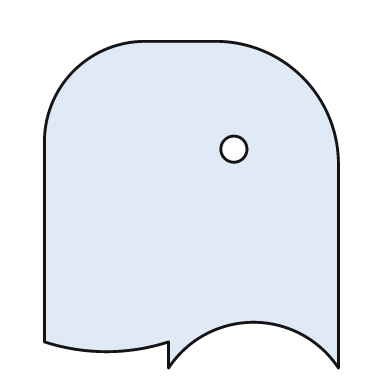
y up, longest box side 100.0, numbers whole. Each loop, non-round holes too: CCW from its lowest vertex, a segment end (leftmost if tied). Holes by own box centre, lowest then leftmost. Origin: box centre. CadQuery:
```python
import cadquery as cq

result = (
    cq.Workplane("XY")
    .moveTo(-7.0, -50.0)
    .threePointArc((19.0, -36.0), (45.0, -50.0))
    .lineTo(45.0, 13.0)
    .threePointArc((34.0, 39.0), (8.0, 50.0))
    .lineTo(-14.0, 50.0)
    .threePointArc((-36.0, 41.0), (-45.0, 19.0))
    .lineTo(-45.0, -42.0)
    .threePointArc((-26.0, -45.0), (-7.0, -42.0))
    .close()
    .moveTo(13.0, 17.0)
    .circle(4.0)
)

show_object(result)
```